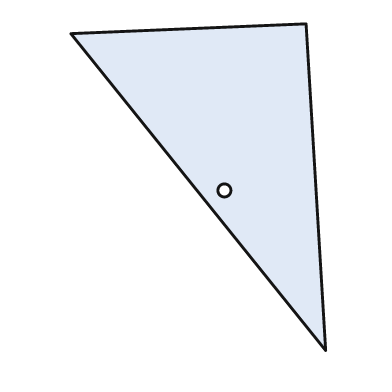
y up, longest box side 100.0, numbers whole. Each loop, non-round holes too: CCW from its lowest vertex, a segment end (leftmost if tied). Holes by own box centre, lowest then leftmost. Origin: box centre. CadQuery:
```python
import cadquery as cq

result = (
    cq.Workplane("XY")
    .moveTo(39.0, -50.0)
    .lineTo(33.0, 50.0)
    .lineTo(-39.0, 47.0)
    .close()
    .moveTo(8.0, -1.0)
    .circle(2.0)
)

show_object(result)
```